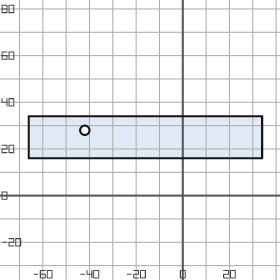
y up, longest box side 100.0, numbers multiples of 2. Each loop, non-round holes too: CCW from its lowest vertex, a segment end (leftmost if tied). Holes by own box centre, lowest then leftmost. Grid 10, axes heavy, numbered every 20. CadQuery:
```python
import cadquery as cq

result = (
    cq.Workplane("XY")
    .moveTo(-66.0, 16.0)
    .lineTo(34.0, 16.0)
    .lineTo(34.0, 34.0)
    .lineTo(-66.0, 34.0)
    .close()
    .moveTo(-42.0, 28.0)
    .circle(2.0)
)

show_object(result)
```